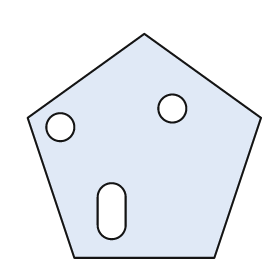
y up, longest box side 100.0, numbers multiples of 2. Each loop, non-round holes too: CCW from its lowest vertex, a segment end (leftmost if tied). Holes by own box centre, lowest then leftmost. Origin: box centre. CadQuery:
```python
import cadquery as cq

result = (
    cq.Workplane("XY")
    .moveTo(-30.0, -48.0)
    .lineTo(30.0, -48.0)
    .lineTo(50.0, 12.0)
    .lineTo(0.0, 48.0)
    .lineTo(-50.0, 12.0)
    .close()
    .moveTo(-20.0, -34.0)
    .threePointArc((-14.0, -40.0), (-8.0, -34.0))
    .lineTo(-8.0, -22.0)
    .threePointArc((-14.0, -16.0), (-20.0, -22.0))
    .close()
    .moveTo(-36.0, 8.0)
    .circle(6.0)
    .moveTo(12.0, 16.0)
    .circle(6.0)
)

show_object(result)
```